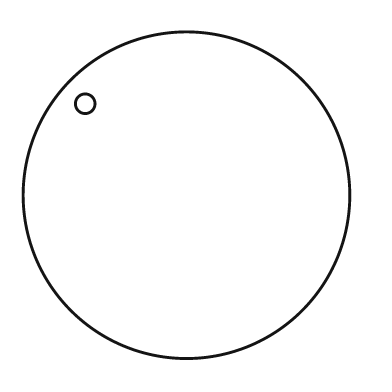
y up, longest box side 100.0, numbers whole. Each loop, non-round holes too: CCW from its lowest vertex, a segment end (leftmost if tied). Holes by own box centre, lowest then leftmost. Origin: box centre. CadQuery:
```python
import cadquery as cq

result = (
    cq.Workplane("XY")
    .moveTo(0.0, 0.0)
    .circle(50.0)
    .moveTo(-31.0, 28.0)
    .circle(3.0)
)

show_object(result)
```